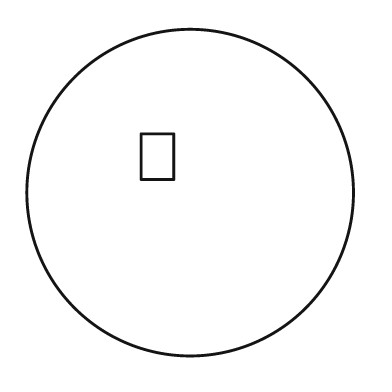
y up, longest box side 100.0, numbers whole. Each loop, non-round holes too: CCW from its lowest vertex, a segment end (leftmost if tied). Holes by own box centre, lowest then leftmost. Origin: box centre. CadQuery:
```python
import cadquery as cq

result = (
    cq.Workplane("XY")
    .moveTo(0.0, 0.0)
    .circle(50.0)
    .moveTo(-15.0, 4.0)
    .lineTo(-5.0, 4.0)
    .lineTo(-5.0, 18.0)
    .lineTo(-15.0, 18.0)
    .close()
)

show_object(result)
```